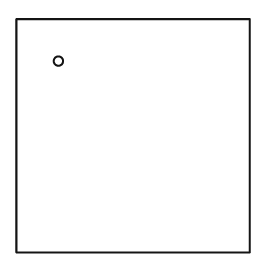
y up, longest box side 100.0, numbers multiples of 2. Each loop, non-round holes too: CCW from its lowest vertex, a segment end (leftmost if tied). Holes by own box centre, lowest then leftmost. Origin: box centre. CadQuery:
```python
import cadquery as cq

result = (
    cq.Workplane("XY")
    .moveTo(-50.0, -50.0)
    .lineTo(50.0, -50.0)
    .lineTo(50.0, 50.0)
    .lineTo(-50.0, 50.0)
    .close()
    .moveTo(-32.0, 32.0)
    .circle(2.0)
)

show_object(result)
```